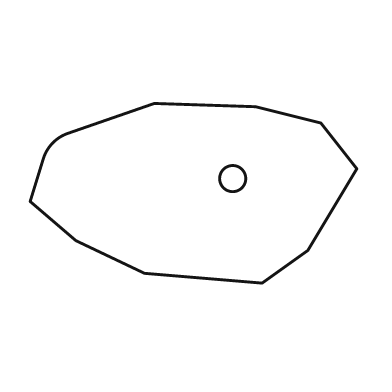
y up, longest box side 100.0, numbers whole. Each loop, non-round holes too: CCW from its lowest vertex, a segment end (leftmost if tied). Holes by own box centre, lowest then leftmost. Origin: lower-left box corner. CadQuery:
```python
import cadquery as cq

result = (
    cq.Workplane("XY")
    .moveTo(71.0, 0.0)
    .lineTo(85.0, 10.0)
    .lineTo(100.0, 35.0)
    .lineTo(89.0, 49.0)
    .lineTo(69.0, 54.0)
    .lineTo(38.0, 55.0)
    .lineTo(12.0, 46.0)
    .threePointArc((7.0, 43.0), (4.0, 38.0))
    .lineTo(0.0, 25.0)
    .lineTo(14.0, 13.0)
    .lineTo(35.0, 3.0)
    .close()
    .moveTo(62.0, 32.0)
    .circle(4.0)
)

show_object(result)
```